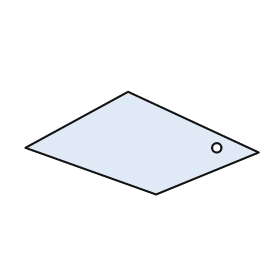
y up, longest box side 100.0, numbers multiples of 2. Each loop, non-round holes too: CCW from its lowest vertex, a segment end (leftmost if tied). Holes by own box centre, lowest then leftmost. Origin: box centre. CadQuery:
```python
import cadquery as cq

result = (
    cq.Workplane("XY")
    .moveTo(6.0, -22.0)
    .lineTo(50.0, -4.0)
    .lineTo(-6.0, 22.0)
    .lineTo(-50.0, -2.0)
    .close()
    .moveTo(32.0, -2.0)
    .circle(2.0)
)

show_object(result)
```